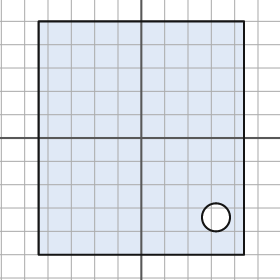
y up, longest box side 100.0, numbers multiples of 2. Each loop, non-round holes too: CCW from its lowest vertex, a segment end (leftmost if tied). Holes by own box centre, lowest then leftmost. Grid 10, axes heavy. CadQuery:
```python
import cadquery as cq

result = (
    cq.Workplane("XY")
    .moveTo(-44.0, -50.0)
    .lineTo(44.0, -50.0)
    .lineTo(44.0, 50.0)
    .lineTo(-44.0, 50.0)
    .close()
    .moveTo(32.0, -34.0)
    .circle(6.0)
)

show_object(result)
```